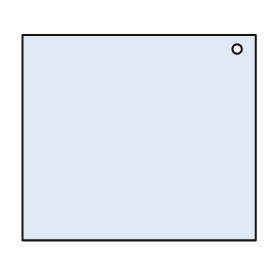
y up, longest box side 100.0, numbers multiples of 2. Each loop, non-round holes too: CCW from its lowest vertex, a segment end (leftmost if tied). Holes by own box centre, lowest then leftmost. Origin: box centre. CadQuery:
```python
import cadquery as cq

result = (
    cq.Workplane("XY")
    .moveTo(-50.0, -44.0)
    .lineTo(50.0, -44.0)
    .lineTo(50.0, 44.0)
    .lineTo(-50.0, 44.0)
    .close()
    .moveTo(42.0, 38.0)
    .circle(2.0)
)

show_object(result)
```